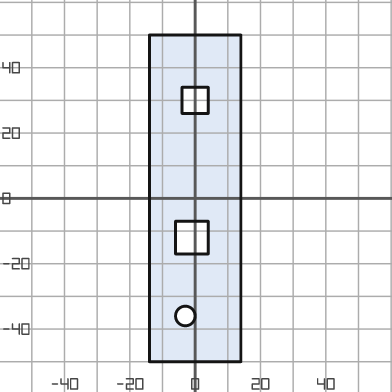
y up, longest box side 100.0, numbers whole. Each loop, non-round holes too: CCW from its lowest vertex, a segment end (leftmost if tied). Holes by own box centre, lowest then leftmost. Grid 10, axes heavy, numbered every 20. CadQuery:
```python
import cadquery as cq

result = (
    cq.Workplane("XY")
    .moveTo(-14.0, -50.0)
    .lineTo(14.0, -50.0)
    .lineTo(14.0, 50.0)
    .lineTo(-14.0, 50.0)
    .close()
    .moveTo(-3.0, -36.0)
    .circle(3.0)
    .moveTo(-6.0, -17.0)
    .lineTo(4.0, -17.0)
    .lineTo(4.0, -7.0)
    .lineTo(-6.0, -7.0)
    .close()
    .moveTo(-4.0, 26.0)
    .lineTo(4.0, 26.0)
    .lineTo(4.0, 34.0)
    .lineTo(-4.0, 34.0)
    .close()
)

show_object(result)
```